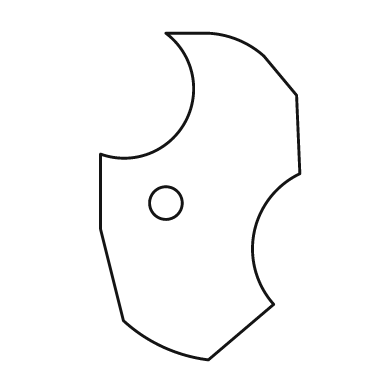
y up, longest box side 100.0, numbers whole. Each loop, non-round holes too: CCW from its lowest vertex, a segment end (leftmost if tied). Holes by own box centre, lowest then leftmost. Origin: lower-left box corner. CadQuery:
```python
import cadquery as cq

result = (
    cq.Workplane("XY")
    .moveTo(33.0, 0.0)
    .lineTo(53.0, 17.0)
    .threePointArc((47.0, 39.0), (61.0, 57.0))
    .lineTo(60.0, 81.0)
    .lineTo(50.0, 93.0)
    .threePointArc((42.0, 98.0), (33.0, 100.0))
    .lineTo(20.0, 100.0)
    .threePointArc((26.0, 73.0), (0.0, 63.0))
    .lineTo(0.0, 40.0)
    .lineTo(7.0, 12.0)
    .threePointArc((19.0, 4.0), (33.0, 0.0))
    .close()
    .moveTo(20.0, 48.0)
    .circle(5.0)
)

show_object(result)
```